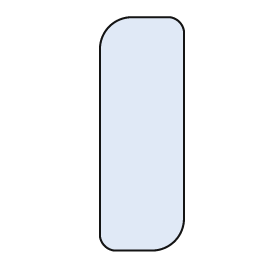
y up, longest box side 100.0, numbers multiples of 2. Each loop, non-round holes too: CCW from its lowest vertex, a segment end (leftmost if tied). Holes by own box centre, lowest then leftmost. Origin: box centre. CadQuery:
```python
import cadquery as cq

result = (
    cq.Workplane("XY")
    .moveTo(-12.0, -50.0)
    .lineTo(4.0, -50.0)
    .threePointArc((14.0, -46.0), (18.0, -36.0))
    .lineTo(18.0, 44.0)
    .threePointArc((16.0, 48.0), (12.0, 50.0))
    .lineTo(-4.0, 50.0)
    .threePointArc((-14.0, 46.0), (-18.0, 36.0))
    .lineTo(-18.0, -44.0)
    .threePointArc((-16.0, -48.0), (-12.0, -50.0))
    .close()
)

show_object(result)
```